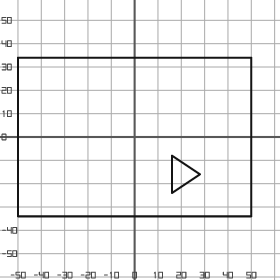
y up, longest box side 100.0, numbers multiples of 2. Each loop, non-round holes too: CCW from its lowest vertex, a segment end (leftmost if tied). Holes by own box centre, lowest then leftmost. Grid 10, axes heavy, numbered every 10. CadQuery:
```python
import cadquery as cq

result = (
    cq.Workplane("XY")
    .moveTo(-50.0, -34.0)
    .lineTo(50.0, -34.0)
    .lineTo(50.0, 34.0)
    .lineTo(-50.0, 34.0)
    .close()
    .moveTo(16.0, -24.0)
    .lineTo(28.0, -16.0)
    .lineTo(16.0, -8.0)
    .close()
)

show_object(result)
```